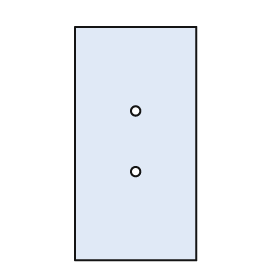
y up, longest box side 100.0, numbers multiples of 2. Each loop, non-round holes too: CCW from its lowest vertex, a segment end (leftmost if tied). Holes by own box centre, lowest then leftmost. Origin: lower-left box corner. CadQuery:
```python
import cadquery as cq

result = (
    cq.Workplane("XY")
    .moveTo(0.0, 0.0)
    .lineTo(52.0, 0.0)
    .lineTo(52.0, 100.0)
    .lineTo(0.0, 100.0)
    .close()
    .moveTo(26.0, 38.0)
    .circle(2.0)
    .moveTo(26.0, 64.0)
    .circle(2.0)
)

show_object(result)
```